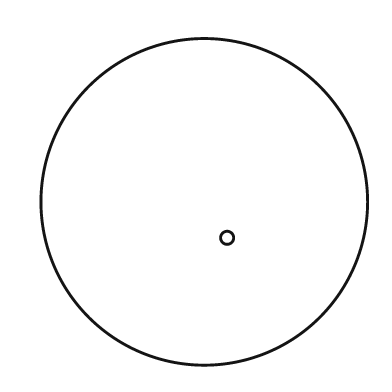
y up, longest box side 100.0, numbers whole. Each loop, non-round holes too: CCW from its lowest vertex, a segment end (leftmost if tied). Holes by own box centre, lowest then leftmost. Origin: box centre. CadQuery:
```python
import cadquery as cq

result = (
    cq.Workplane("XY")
    .moveTo(0.0, 0.0)
    .circle(50.0)
    .moveTo(7.0, -11.0)
    .circle(2.0)
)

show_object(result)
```